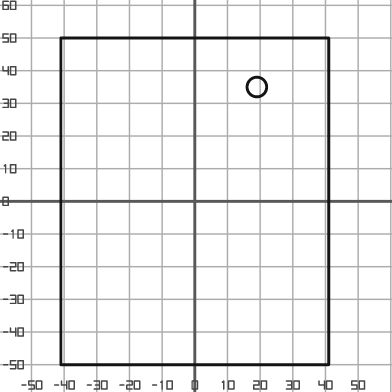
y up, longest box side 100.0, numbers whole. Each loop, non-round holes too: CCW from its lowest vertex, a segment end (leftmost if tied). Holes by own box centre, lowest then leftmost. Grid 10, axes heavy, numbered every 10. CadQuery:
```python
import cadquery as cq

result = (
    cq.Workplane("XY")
    .moveTo(-41.0, -50.0)
    .lineTo(41.0, -50.0)
    .lineTo(41.0, 50.0)
    .lineTo(-41.0, 50.0)
    .close()
    .moveTo(19.0, 35.0)
    .circle(3.0)
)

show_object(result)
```